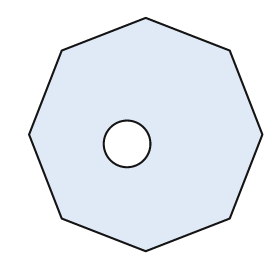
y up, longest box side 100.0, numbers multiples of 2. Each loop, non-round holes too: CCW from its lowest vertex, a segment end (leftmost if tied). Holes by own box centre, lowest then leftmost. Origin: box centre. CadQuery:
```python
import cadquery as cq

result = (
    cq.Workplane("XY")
    .moveTo(0.0, -50.0)
    .lineTo(36.0, -36.0)
    .lineTo(50.0, 0.0)
    .lineTo(36.0, 36.0)
    .lineTo(0.0, 50.0)
    .lineTo(-36.0, 36.0)
    .lineTo(-50.0, 0.0)
    .lineTo(-36.0, -36.0)
    .close()
    .moveTo(-8.0, -4.0)
    .circle(10.0)
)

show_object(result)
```